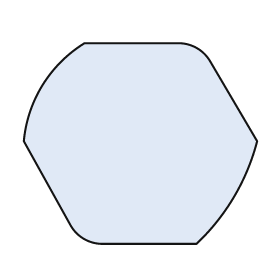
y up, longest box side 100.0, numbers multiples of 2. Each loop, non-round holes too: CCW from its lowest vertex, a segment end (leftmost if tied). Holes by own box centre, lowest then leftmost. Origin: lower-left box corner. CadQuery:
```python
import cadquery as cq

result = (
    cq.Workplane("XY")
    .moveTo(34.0, 0.0)
    .lineTo(74.0, 0.0)
    .threePointArc((90.0, 20.0), (100.0, 44.0))
    .lineTo(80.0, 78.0)
    .threePointArc((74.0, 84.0), (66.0, 86.0))
    .lineTo(26.0, 86.0)
    .threePointArc((8.0, 68.0), (0.0, 44.0))
    .lineTo(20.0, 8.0)
    .threePointArc((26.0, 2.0), (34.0, 0.0))
    .close()
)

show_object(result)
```